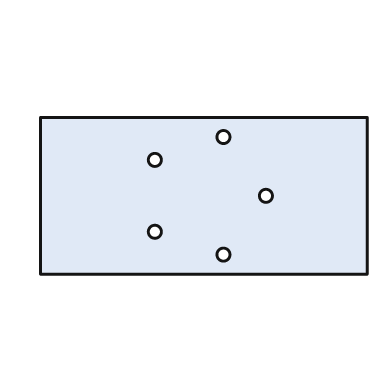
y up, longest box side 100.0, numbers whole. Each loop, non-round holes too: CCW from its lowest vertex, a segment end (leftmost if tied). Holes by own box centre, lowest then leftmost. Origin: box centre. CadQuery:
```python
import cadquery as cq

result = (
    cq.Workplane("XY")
    .moveTo(-50.0, -24.0)
    .lineTo(50.0, -24.0)
    .lineTo(50.0, 24.0)
    .lineTo(-50.0, 24.0)
    .close()
    .moveTo(6.0, -18.0)
    .circle(2.0)
    .moveTo(-15.0, -11.0)
    .circle(2.0)
    .moveTo(19.0, 0.0)
    .circle(2.0)
    .moveTo(-15.0, 11.0)
    .circle(2.0)
    .moveTo(6.0, 18.0)
    .circle(2.0)
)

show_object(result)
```